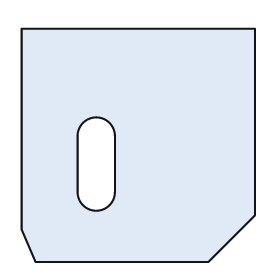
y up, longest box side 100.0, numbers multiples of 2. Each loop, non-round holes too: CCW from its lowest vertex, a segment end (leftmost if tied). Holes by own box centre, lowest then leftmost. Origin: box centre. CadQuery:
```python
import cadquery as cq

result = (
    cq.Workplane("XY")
    .moveTo(-44.0, -50.0)
    .lineTo(30.0, -50.0)
    .lineTo(50.0, -30.0)
    .lineTo(50.0, 50.0)
    .lineTo(-50.0, 50.0)
    .lineTo(-50.0, -36.0)
    .close()
    .moveTo(-26.0, -20.0)
    .threePointArc((-18.0, -28.0), (-10.0, -20.0))
    .lineTo(-10.0, 4.0)
    .threePointArc((-18.0, 12.0), (-26.0, 4.0))
    .close()
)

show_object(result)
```